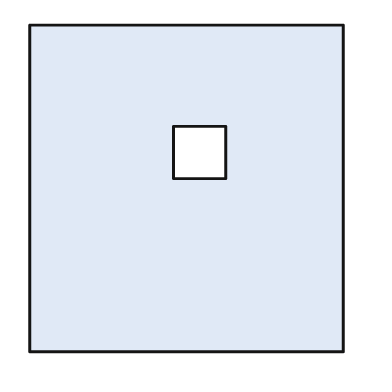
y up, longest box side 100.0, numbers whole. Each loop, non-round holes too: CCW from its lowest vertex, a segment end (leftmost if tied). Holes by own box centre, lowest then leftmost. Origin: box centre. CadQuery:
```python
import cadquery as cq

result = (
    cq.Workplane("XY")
    .moveTo(-48.0, -50.0)
    .lineTo(48.0, -50.0)
    .lineTo(48.0, 50.0)
    .lineTo(-48.0, 50.0)
    .close()
    .moveTo(-4.0, 3.0)
    .lineTo(12.0, 3.0)
    .lineTo(12.0, 19.0)
    .lineTo(-4.0, 19.0)
    .close()
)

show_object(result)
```